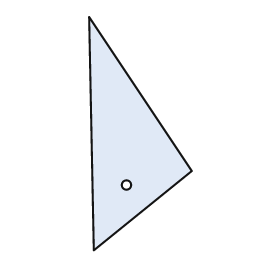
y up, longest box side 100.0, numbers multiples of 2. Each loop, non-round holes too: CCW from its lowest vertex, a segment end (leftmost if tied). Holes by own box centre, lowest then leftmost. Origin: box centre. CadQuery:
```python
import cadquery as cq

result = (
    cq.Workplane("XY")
    .moveTo(-20.0, -50.0)
    .lineTo(22.0, -16.0)
    .lineTo(-22.0, 50.0)
    .close()
    .moveTo(-6.0, -22.0)
    .circle(2.0)
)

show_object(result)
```